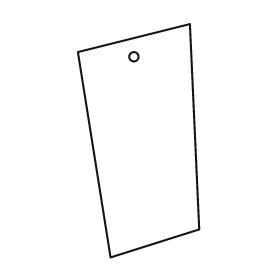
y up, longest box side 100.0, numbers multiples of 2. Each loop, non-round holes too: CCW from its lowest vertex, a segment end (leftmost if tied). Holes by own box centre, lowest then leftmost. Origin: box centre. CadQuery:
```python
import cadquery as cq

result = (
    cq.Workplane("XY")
    .moveTo(-12.0, -50.0)
    .lineTo(26.0, -38.0)
    .lineTo(22.0, 50.0)
    .lineTo(-26.0, 38.0)
    .close()
    .moveTo(-2.0, 36.0)
    .circle(2.0)
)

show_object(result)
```